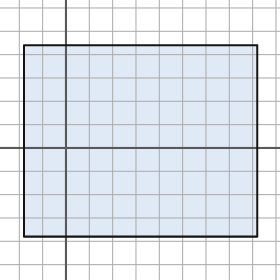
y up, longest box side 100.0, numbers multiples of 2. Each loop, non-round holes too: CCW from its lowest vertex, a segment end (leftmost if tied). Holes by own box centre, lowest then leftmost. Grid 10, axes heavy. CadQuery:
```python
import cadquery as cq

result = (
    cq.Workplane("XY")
    .moveTo(-18.0, -38.0)
    .lineTo(82.0, -38.0)
    .lineTo(82.0, 44.0)
    .lineTo(-18.0, 44.0)
    .close()
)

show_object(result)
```